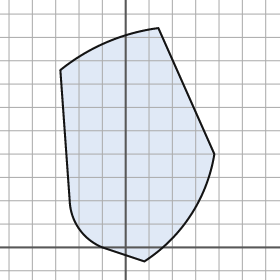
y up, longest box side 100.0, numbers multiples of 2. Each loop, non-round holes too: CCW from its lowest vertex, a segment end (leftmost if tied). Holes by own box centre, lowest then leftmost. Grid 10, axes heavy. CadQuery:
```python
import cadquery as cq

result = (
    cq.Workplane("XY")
    .moveTo(8.0, -6.0)
    .threePointArc((28.0, 14.0), (38.0, 40.0))
    .lineTo(14.0, 94.0)
    .threePointArc((-8.0, 88.0), (-28.0, 76.0))
    .lineTo(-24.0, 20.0)
    .threePointArc((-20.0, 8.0), (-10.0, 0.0))
    .close()
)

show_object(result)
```